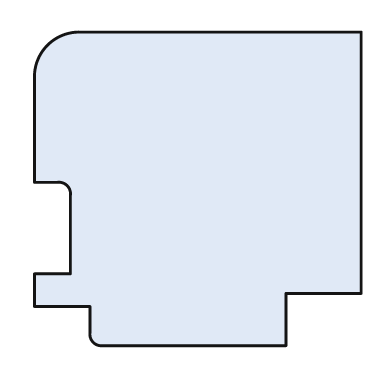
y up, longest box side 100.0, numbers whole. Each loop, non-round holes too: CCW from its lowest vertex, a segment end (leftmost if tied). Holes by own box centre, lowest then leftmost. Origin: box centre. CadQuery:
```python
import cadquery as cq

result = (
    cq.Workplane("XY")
    .moveTo(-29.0, -48.0)
    .lineTo(27.0, -48.0)
    .lineTo(27.0, -32.0)
    .lineTo(50.0, -32.0)
    .lineTo(50.0, 48.0)
    .lineTo(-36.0, 48.0)
    .threePointArc((-46.0, 44.0), (-50.0, 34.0))
    .lineTo(-50.0, 2.0)
    .lineTo(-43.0, 2.0)
    .threePointArc((-40.0, 1.0), (-39.0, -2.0))
    .lineTo(-39.0, -26.0)
    .lineTo(-50.0, -26.0)
    .lineTo(-50.0, -36.0)
    .lineTo(-33.0, -36.0)
    .lineTo(-33.0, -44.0)
    .threePointArc((-32.0, -47.0), (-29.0, -48.0))
    .close()
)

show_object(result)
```